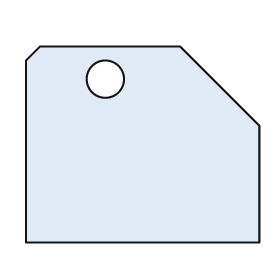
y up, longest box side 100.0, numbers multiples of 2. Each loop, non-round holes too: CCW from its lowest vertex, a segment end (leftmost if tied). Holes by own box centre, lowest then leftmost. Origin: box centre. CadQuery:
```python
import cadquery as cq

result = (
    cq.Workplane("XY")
    .moveTo(-50.0, -42.0)
    .lineTo(50.0, -42.0)
    .lineTo(50.0, 8.0)
    .lineTo(16.0, 42.0)
    .lineTo(-44.0, 42.0)
    .lineTo(-50.0, 36.0)
    .close()
    .moveTo(-16.0, 28.0)
    .circle(8.0)
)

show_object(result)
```